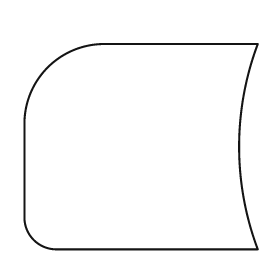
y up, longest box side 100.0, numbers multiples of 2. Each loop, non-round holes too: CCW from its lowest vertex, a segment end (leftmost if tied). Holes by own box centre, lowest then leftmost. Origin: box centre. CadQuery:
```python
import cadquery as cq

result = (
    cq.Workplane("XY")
    .moveTo(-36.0, -44.0)
    .lineTo(50.0, -44.0)
    .threePointArc((42.0, 0.0), (50.0, 44.0))
    .lineTo(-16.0, 44.0)
    .threePointArc((-40.0, 34.0), (-50.0, 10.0))
    .lineTo(-50.0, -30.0)
    .threePointArc((-46.0, -40.0), (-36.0, -44.0))
    .close()
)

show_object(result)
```